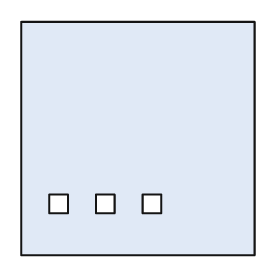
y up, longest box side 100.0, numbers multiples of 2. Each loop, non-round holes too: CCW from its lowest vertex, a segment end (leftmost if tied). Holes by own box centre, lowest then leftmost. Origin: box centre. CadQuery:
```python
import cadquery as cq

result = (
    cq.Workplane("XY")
    .moveTo(-50.0, -50.0)
    .lineTo(50.0, -50.0)
    .lineTo(50.0, 50.0)
    .lineTo(-50.0, 50.0)
    .close()
    .moveTo(-38.0, -32.0)
    .lineTo(-30.0, -32.0)
    .lineTo(-30.0, -24.0)
    .lineTo(-38.0, -24.0)
    .close()
    .moveTo(-18.0, -32.0)
    .lineTo(-10.0, -32.0)
    .lineTo(-10.0, -24.0)
    .lineTo(-18.0, -24.0)
    .close()
    .moveTo(2.0, -32.0)
    .lineTo(10.0, -32.0)
    .lineTo(10.0, -24.0)
    .lineTo(2.0, -24.0)
    .close()
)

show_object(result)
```